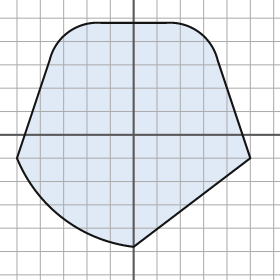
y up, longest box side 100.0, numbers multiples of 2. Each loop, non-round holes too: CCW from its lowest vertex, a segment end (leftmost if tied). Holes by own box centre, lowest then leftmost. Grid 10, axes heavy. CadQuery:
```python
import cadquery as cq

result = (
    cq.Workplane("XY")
    .moveTo(0.0, -48.0)
    .lineTo(50.0, -10.0)
    .lineTo(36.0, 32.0)
    .threePointArc((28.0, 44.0), (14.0, 48.0))
    .lineTo(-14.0, 48.0)
    .threePointArc((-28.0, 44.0), (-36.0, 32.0))
    .lineTo(-50.0, -10.0)
    .threePointArc((-30.0, -36.0), (0.0, -48.0))
    .close()
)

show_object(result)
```